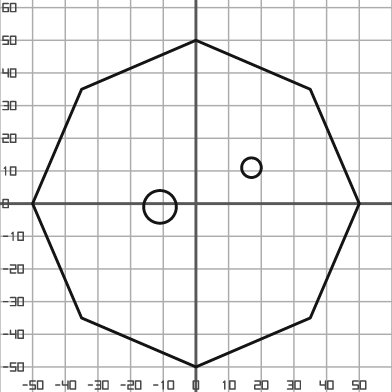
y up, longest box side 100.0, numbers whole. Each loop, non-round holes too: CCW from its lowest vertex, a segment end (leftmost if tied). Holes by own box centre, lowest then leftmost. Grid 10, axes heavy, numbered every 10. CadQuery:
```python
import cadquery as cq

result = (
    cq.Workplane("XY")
    .moveTo(0.0, -50.0)
    .lineTo(35.0, -35.0)
    .lineTo(50.0, 0.0)
    .lineTo(35.0, 35.0)
    .lineTo(0.0, 50.0)
    .lineTo(-35.0, 35.0)
    .lineTo(-50.0, 0.0)
    .lineTo(-35.0, -35.0)
    .close()
    .moveTo(-11.0, -1.0)
    .circle(5.0)
    .moveTo(17.0, 11.0)
    .circle(3.0)
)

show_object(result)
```